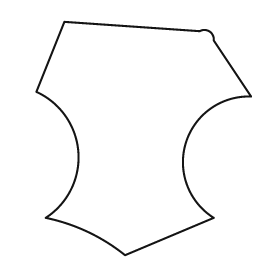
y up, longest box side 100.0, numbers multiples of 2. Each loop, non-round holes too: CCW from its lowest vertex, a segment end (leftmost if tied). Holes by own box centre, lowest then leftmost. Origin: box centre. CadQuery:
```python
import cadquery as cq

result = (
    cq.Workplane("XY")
    .moveTo(-8.0, -50.0)
    .lineTo(30.0, -34.0)
    .threePointArc((18.0, -2.0), (46.0, 18.0))
    .lineTo(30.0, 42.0)
    .threePointArc((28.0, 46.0), (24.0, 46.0))
    .lineTo(-34.0, 50.0)
    .lineTo(-46.0, 20.0)
    .threePointArc((-28.0, -6.0), (-42.0, -34.0))
    .threePointArc((-24.0, -40.0), (-8.0, -50.0))
    .close()
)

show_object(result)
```